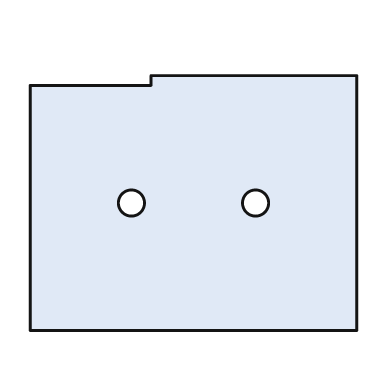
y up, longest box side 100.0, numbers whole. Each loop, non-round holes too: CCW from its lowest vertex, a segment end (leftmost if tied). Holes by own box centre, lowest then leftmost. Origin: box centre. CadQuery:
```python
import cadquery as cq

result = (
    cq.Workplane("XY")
    .moveTo(-50.0, -39.0)
    .lineTo(50.0, -39.0)
    .lineTo(50.0, 39.0)
    .lineTo(-13.0, 39.0)
    .lineTo(-13.0, 36.0)
    .lineTo(-50.0, 36.0)
    .close()
    .moveTo(-19.0, 0.0)
    .circle(4.0)
    .moveTo(19.0, 0.0)
    .circle(4.0)
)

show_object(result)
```